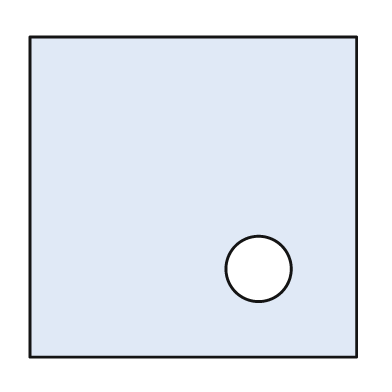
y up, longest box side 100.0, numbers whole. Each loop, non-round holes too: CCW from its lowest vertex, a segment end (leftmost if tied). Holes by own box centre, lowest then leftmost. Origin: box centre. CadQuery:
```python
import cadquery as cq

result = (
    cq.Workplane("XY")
    .moveTo(-50.0, -49.0)
    .lineTo(50.0, -49.0)
    .lineTo(50.0, 49.0)
    .lineTo(-50.0, 49.0)
    .close()
    .moveTo(20.0, -22.0)
    .circle(10.0)
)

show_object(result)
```